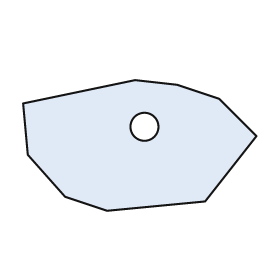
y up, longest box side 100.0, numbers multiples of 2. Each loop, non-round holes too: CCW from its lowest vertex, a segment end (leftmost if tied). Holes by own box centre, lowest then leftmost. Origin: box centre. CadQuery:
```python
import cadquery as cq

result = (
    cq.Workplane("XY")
    .moveTo(-14.0, -28.0)
    .lineTo(28.0, -24.0)
    .lineTo(50.0, 4.0)
    .lineTo(34.0, 20.0)
    .lineTo(16.0, 26.0)
    .lineTo(-2.0, 28.0)
    .lineTo(-50.0, 18.0)
    .lineTo(-48.0, -4.0)
    .lineTo(-32.0, -22.0)
    .close()
    .moveTo(2.0, 8.0)
    .circle(6.0)
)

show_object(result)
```